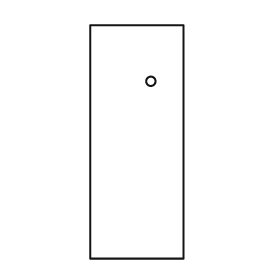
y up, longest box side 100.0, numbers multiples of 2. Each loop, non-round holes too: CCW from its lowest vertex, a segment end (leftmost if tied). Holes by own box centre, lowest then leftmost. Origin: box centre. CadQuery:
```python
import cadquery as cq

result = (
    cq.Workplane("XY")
    .moveTo(-20.0, -50.0)
    .lineTo(20.0, -50.0)
    .lineTo(20.0, 50.0)
    .lineTo(-20.0, 50.0)
    .close()
    .moveTo(6.0, 26.0)
    .circle(2.0)
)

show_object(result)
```